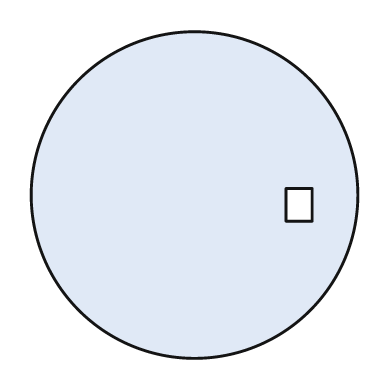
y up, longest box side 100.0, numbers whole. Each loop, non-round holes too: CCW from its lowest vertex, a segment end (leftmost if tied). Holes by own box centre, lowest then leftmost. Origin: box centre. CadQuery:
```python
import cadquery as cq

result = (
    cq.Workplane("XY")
    .moveTo(0.0, 0.0)
    .circle(50.0)
    .moveTo(28.0, -8.0)
    .lineTo(36.0, -8.0)
    .lineTo(36.0, 2.0)
    .lineTo(28.0, 2.0)
    .close()
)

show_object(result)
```